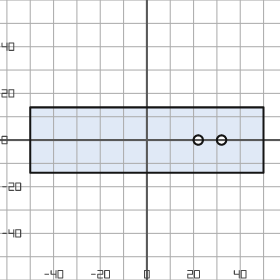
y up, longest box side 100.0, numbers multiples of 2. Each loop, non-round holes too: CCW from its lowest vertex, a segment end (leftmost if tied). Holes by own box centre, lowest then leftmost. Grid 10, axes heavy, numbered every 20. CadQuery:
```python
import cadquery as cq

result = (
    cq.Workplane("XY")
    .moveTo(-50.0, -14.0)
    .lineTo(50.0, -14.0)
    .lineTo(50.0, 14.0)
    .lineTo(-50.0, 14.0)
    .close()
    .moveTo(22.0, 0.0)
    .circle(2.0)
    .moveTo(32.0, 0.0)
    .circle(2.0)
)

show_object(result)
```